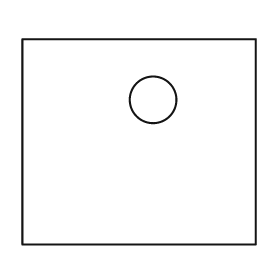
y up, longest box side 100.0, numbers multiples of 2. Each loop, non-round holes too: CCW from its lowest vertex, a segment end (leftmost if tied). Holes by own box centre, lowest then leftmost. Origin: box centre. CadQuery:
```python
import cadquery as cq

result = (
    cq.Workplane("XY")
    .moveTo(-50.0, -44.0)
    .lineTo(50.0, -44.0)
    .lineTo(50.0, 44.0)
    .lineTo(-50.0, 44.0)
    .close()
    .moveTo(6.0, 18.0)
    .circle(10.0)
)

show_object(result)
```